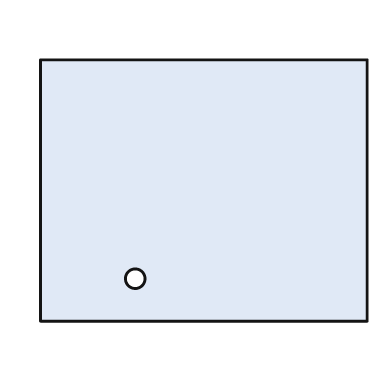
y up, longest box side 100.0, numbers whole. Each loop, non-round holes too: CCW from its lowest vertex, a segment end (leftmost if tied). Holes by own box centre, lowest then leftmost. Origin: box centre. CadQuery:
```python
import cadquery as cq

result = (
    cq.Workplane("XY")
    .moveTo(-50.0, -40.0)
    .lineTo(50.0, -40.0)
    .lineTo(50.0, 40.0)
    .lineTo(-50.0, 40.0)
    .close()
    .moveTo(-21.0, -27.0)
    .circle(3.0)
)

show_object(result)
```